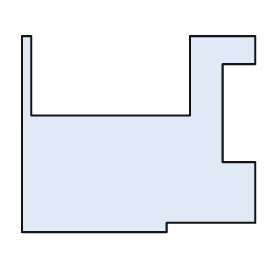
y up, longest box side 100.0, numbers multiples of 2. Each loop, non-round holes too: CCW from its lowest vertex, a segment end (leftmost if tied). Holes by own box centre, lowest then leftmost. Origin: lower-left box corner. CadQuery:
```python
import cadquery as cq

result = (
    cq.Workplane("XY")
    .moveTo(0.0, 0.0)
    .lineTo(62.0, 0.0)
    .lineTo(62.0, 4.0)
    .lineTo(100.0, 4.0)
    .lineTo(100.0, 30.0)
    .lineTo(86.0, 30.0)
    .lineTo(86.0, 72.0)
    .lineTo(100.0, 72.0)
    .lineTo(100.0, 84.0)
    .lineTo(72.0, 84.0)
    .lineTo(72.0, 50.0)
    .lineTo(4.0, 50.0)
    .lineTo(4.0, 84.0)
    .lineTo(0.0, 84.0)
    .close()
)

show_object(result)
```